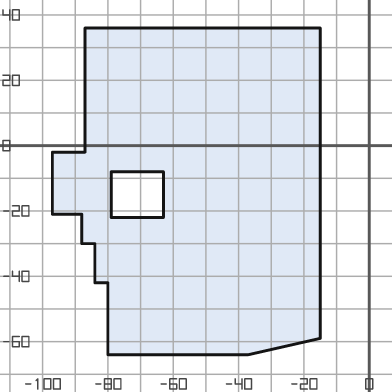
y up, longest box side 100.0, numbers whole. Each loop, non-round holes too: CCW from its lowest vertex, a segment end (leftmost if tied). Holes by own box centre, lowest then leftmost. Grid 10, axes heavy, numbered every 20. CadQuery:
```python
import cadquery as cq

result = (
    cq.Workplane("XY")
    .moveTo(-80.0, -64.0)
    .lineTo(-37.0, -64.0)
    .lineTo(-15.0, -59.0)
    .lineTo(-15.0, 36.0)
    .lineTo(-87.0, 36.0)
    .lineTo(-87.0, -2.0)
    .lineTo(-97.0, -2.0)
    .lineTo(-97.0, -21.0)
    .lineTo(-88.0, -21.0)
    .lineTo(-88.0, -30.0)
    .lineTo(-84.0, -30.0)
    .lineTo(-84.0, -42.0)
    .lineTo(-80.0, -42.0)
    .close()
    .moveTo(-79.0, -22.0)
    .lineTo(-63.0, -22.0)
    .lineTo(-63.0, -8.0)
    .lineTo(-79.0, -8.0)
    .close()
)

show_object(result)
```